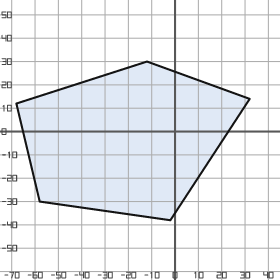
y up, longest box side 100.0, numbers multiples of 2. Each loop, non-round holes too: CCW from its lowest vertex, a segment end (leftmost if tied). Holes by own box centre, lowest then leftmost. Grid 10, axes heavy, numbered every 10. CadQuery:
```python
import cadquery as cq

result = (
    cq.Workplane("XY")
    .moveTo(-2.0, -38.0)
    .lineTo(32.0, 14.0)
    .lineTo(-12.0, 30.0)
    .lineTo(-68.0, 12.0)
    .lineTo(-58.0, -30.0)
    .close()
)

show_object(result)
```